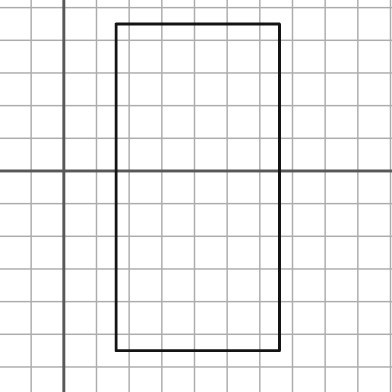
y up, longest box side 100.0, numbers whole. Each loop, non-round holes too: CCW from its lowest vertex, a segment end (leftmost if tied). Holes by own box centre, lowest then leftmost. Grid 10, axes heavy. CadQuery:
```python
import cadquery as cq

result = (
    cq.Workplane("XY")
    .moveTo(16.0, -55.0)
    .lineTo(66.0, -55.0)
    .lineTo(66.0, 45.0)
    .lineTo(16.0, 45.0)
    .close()
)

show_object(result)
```